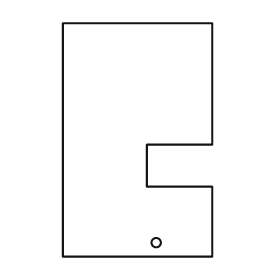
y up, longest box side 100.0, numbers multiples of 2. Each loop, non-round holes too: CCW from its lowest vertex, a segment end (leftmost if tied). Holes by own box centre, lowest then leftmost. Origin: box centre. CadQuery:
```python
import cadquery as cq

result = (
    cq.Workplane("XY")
    .moveTo(-32.0, -50.0)
    .lineTo(32.0, -50.0)
    .lineTo(32.0, -20.0)
    .lineTo(4.0, -20.0)
    .lineTo(4.0, -2.0)
    .lineTo(32.0, -2.0)
    .lineTo(32.0, 50.0)
    .lineTo(-32.0, 50.0)
    .close()
    .moveTo(8.0, -44.0)
    .circle(2.0)
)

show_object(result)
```